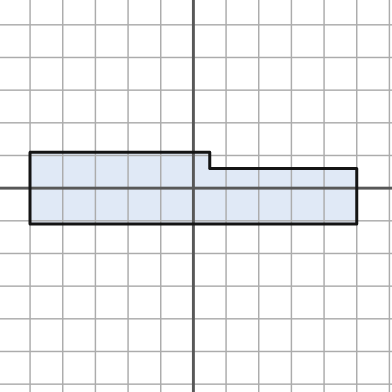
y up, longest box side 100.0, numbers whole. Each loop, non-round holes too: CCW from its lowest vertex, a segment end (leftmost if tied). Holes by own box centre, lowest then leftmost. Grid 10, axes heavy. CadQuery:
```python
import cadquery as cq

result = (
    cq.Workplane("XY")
    .moveTo(-50.0, -11.0)
    .lineTo(50.0, -11.0)
    .lineTo(50.0, 6.0)
    .lineTo(5.0, 6.0)
    .lineTo(5.0, 11.0)
    .lineTo(-50.0, 11.0)
    .close()
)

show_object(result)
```